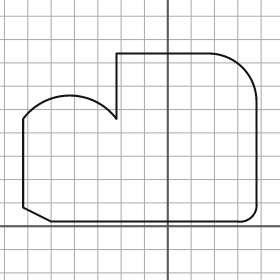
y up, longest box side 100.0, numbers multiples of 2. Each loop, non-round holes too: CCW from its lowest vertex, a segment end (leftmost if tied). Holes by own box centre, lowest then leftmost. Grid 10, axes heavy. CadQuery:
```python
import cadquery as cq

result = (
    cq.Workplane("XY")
    .moveTo(-50.0, 2.0)
    .lineTo(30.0, 2.0)
    .threePointArc((36.0, 4.0), (38.0, 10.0))
    .lineTo(38.0, 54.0)
    .threePointArc((32.0, 68.0), (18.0, 74.0))
    .lineTo(-22.0, 74.0)
    .lineTo(-22.0, 46.0)
    .threePointArc((-42.0, 56.0), (-62.0, 46.0))
    .lineTo(-62.0, 8.0)
    .close()
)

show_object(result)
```